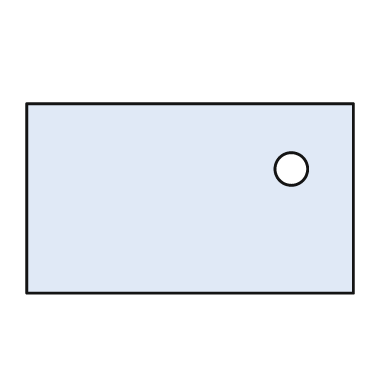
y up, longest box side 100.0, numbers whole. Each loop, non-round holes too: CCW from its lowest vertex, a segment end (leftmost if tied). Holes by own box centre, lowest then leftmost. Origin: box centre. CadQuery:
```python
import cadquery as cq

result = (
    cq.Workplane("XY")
    .moveTo(-50.0, -29.0)
    .lineTo(50.0, -29.0)
    .lineTo(50.0, 29.0)
    .lineTo(-50.0, 29.0)
    .close()
    .moveTo(31.0, 9.0)
    .circle(5.0)
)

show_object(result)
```